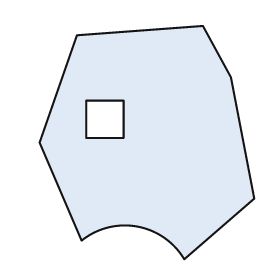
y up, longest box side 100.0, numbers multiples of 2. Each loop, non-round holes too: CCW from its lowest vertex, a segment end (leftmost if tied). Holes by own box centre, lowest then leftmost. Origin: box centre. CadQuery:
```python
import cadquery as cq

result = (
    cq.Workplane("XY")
    .moveTo(16.0, -50.0)
    .lineTo(46.0, -24.0)
    .lineTo(36.0, 28.0)
    .lineTo(24.0, 50.0)
    .lineTo(-30.0, 46.0)
    .lineTo(-46.0, 0.0)
    .lineTo(-28.0, -42.0)
    .threePointArc((-4.0, -36.0), (16.0, -50.0))
    .close()
    .moveTo(-26.0, 2.0)
    .lineTo(-10.0, 2.0)
    .lineTo(-10.0, 18.0)
    .lineTo(-26.0, 18.0)
    .close()
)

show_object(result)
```